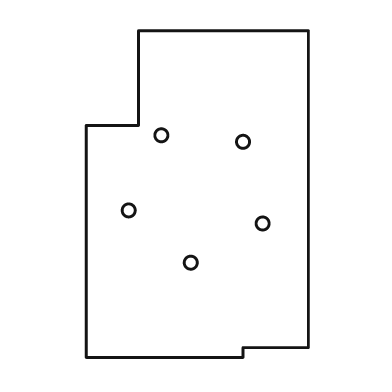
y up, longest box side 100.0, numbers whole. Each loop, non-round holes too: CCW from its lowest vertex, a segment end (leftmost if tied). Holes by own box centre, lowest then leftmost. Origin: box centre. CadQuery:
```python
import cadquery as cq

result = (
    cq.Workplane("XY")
    .moveTo(-34.0, -50.0)
    .lineTo(14.0, -50.0)
    .lineTo(14.0, -47.0)
    .lineTo(34.0, -47.0)
    .lineTo(34.0, 50.0)
    .lineTo(-18.0, 50.0)
    .lineTo(-18.0, 21.0)
    .lineTo(-34.0, 21.0)
    .close()
    .moveTo(-2.0, -21.0)
    .circle(2.0)
    .moveTo(20.0, -9.0)
    .circle(2.0)
    .moveTo(-21.0, -5.0)
    .circle(2.0)
    .moveTo(14.0, 16.0)
    .circle(2.0)
    .moveTo(-11.0, 18.0)
    .circle(2.0)
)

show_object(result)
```